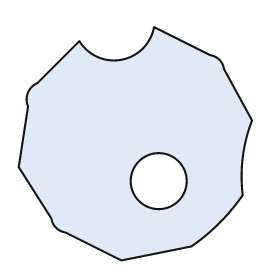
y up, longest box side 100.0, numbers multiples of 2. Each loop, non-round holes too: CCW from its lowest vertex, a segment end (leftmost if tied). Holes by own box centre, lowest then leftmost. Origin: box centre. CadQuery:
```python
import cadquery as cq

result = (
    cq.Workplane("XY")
    .moveTo(-6.0, -50.0)
    .lineTo(24.0, -44.0)
    .threePointArc((36.0, -34.0), (46.0, -22.0))
    .threePointArc((46.0, -6.0), (50.0, 10.0))
    .lineTo(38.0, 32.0)
    .threePointArc((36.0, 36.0), (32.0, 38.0))
    .lineTo(8.0, 50.0)
    .threePointArc((-6.0, 36.0), (-24.0, 44.0))
    .lineTo(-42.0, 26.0)
    .threePointArc((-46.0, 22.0), (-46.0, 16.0))
    .lineTo(-50.0, -10.0)
    .lineTo(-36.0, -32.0)
    .threePointArc((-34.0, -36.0), (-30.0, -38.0))
    .close()
    .moveTo(10.0, -16.0)
    .circle(12.0)
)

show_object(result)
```